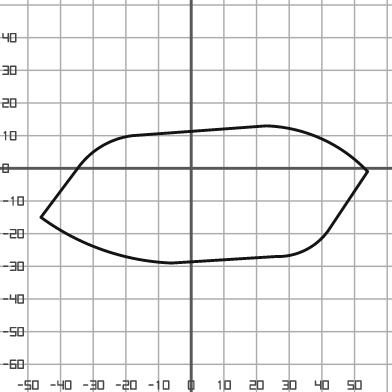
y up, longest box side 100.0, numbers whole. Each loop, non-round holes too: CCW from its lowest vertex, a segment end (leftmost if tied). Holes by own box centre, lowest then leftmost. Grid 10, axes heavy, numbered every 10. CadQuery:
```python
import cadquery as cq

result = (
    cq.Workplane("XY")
    .moveTo(-6.0, -29.0)
    .lineTo(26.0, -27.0)
    .threePointArc((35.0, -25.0), (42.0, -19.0))
    .lineTo(54.0, -1.0)
    .threePointArc((40.0, 9.0), (23.0, 13.0))
    .lineTo(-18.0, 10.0)
    .threePointArc((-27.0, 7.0), (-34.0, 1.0))
    .lineTo(-46.0, -15.0)
    .threePointArc((-27.0, -25.0), (-6.0, -29.0))
    .close()
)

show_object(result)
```